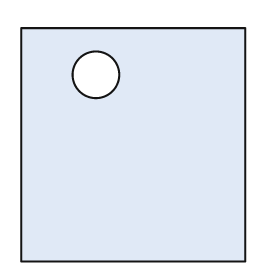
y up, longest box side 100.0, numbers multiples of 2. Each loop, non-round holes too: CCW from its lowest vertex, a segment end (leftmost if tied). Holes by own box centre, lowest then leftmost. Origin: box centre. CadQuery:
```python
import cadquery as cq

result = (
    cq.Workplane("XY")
    .moveTo(-48.0, -50.0)
    .lineTo(48.0, -50.0)
    .lineTo(48.0, 50.0)
    .lineTo(-48.0, 50.0)
    .close()
    .moveTo(-16.0, 30.0)
    .circle(10.0)
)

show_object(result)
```